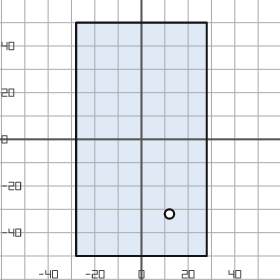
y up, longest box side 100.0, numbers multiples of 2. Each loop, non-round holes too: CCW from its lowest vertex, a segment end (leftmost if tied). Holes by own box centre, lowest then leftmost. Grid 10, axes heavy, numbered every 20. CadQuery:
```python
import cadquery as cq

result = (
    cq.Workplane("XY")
    .moveTo(-28.0, -50.0)
    .lineTo(28.0, -50.0)
    .lineTo(28.0, 50.0)
    .lineTo(-28.0, 50.0)
    .close()
    .moveTo(12.0, -32.0)
    .circle(2.0)
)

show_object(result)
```